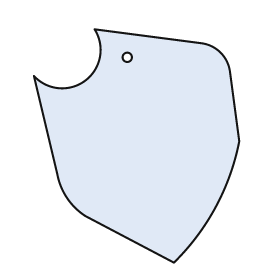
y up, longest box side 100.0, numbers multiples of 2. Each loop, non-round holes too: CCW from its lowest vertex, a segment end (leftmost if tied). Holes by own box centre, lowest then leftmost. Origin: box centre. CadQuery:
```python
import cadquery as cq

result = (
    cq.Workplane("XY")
    .moveTo(16.0, -50.0)
    .threePointArc((34.0, -26.0), (44.0, 2.0))
    .lineTo(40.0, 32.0)
    .threePointArc((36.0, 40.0), (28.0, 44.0))
    .lineTo(-18.0, 50.0)
    .threePointArc((-22.0, 28.0), (-44.0, 30.0))
    .lineTo(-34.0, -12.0)
    .threePointArc((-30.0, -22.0), (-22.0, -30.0))
    .close()
    .moveTo(-4.0, 38.0)
    .circle(2.0)
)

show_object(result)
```